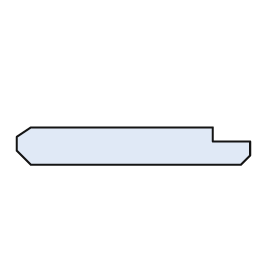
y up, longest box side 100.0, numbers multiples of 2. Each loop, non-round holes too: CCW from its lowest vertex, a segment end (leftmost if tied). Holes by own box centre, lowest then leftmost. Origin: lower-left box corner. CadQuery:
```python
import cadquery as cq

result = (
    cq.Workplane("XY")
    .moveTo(6.0, 0.0)
    .lineTo(96.0, 0.0)
    .lineTo(100.0, 4.0)
    .lineTo(100.0, 10.0)
    .lineTo(84.0, 10.0)
    .lineTo(84.0, 16.0)
    .lineTo(6.0, 16.0)
    .lineTo(0.0, 12.0)
    .lineTo(0.0, 6.0)
    .close()
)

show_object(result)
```